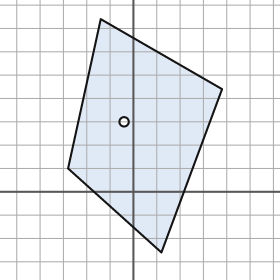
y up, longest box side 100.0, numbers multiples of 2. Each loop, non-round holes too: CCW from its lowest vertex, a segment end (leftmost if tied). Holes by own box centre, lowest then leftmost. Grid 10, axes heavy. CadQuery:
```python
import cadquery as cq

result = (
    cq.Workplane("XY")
    .moveTo(12.0, -26.0)
    .lineTo(38.0, 44.0)
    .lineTo(-14.0, 74.0)
    .lineTo(-28.0, 10.0)
    .close()
    .moveTo(-4.0, 30.0)
    .circle(2.0)
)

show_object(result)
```